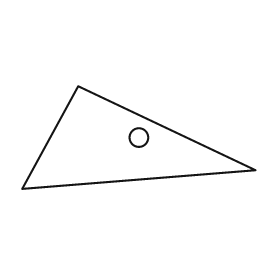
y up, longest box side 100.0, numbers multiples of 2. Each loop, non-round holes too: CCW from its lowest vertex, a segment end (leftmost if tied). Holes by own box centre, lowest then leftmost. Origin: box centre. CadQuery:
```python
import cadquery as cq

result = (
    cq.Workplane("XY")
    .moveTo(-50.0, -22.0)
    .lineTo(50.0, -14.0)
    .lineTo(-26.0, 22.0)
    .close()
    .moveTo(0.0, 0.0)
    .circle(4.0)
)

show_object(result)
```